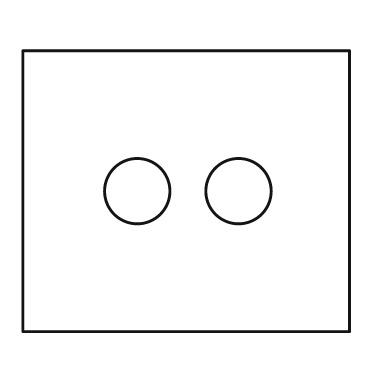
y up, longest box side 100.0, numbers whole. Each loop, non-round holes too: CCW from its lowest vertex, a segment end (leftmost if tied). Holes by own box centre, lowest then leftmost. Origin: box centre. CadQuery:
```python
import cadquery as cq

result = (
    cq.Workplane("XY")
    .moveTo(-50.0, -43.0)
    .lineTo(50.0, -43.0)
    .lineTo(50.0, 43.0)
    .lineTo(-50.0, 43.0)
    .close()
    .moveTo(-15.0, 0.0)
    .circle(10.0)
    .moveTo(16.0, 0.0)
    .circle(10.0)
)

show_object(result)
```